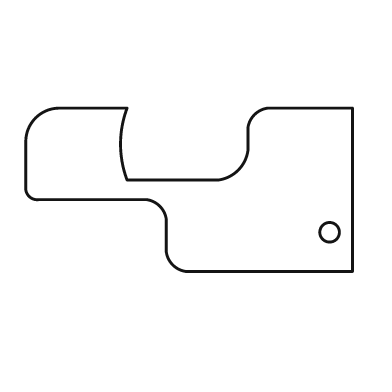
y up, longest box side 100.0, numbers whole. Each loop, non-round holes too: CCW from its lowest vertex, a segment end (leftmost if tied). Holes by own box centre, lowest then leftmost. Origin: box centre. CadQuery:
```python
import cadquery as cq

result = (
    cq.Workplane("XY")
    .moveTo(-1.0, -25.0)
    .lineTo(50.0, -25.0)
    .lineTo(50.0, 25.0)
    .lineTo(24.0, 25.0)
    .threePointArc((20.0, 23.0), (18.0, 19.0))
    .lineTo(18.0, 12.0)
    .threePointArc((15.0, 6.0), (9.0, 3.0))
    .lineTo(-19.0, 3.0)
    .threePointArc((-21.0, 14.0), (-19.0, 25.0))
    .lineTo(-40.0, 25.0)
    .threePointArc((-47.0, 22.0), (-50.0, 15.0))
    .lineTo(-50.0, 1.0)
    .threePointArc((-49.0, -2.0), (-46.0, -3.0))
    .lineTo(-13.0, -3.0)
    .threePointArc((-9.0, -5.0), (-7.0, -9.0))
    .lineTo(-7.0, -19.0)
    .threePointArc((-5.0, -23.0), (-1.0, -25.0))
    .close()
    .moveTo(43.0, -13.0)
    .circle(3.0)
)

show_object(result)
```